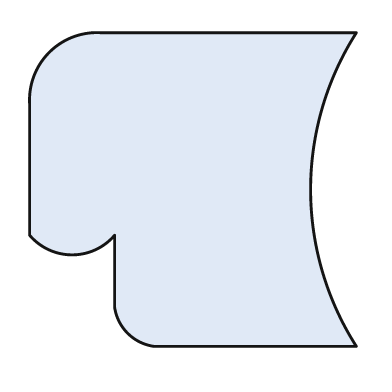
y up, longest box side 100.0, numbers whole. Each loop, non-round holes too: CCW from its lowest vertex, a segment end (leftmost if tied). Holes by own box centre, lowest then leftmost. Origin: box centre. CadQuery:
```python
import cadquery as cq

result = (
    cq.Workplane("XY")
    .moveTo(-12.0, -48.0)
    .lineTo(50.0, -48.0)
    .threePointArc((36.0, 0.0), (50.0, 48.0))
    .lineTo(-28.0, 48.0)
    .threePointArc((-44.0, 42.0), (-50.0, 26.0))
    .lineTo(-50.0, -14.0)
    .threePointArc((-37.0, -20.0), (-24.0, -14.0))
    .lineTo(-24.0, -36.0)
    .threePointArc((-20.0, -44.0), (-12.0, -48.0))
    .close()
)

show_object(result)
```